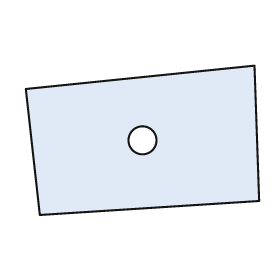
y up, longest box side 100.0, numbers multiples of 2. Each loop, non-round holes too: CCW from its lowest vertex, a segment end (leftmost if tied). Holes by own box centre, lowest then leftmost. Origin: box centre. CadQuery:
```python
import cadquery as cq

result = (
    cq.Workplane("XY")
    .moveTo(-44.0, -32.0)
    .lineTo(50.0, -26.0)
    .lineTo(48.0, 32.0)
    .lineTo(-50.0, 22.0)
    .close()
    .moveTo(0.0, 0.0)
    .circle(6.0)
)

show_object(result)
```